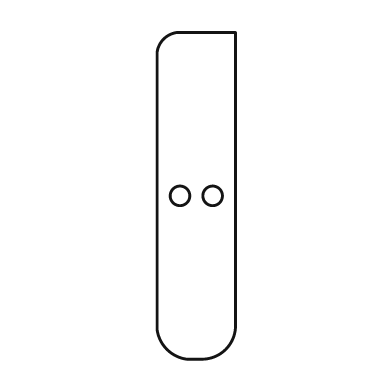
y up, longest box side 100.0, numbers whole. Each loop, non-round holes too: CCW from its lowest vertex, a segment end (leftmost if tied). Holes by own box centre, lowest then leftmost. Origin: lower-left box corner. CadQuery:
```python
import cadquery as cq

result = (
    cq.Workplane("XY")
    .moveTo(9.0, 0.0)
    .lineTo(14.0, 0.0)
    .threePointArc((21.0, 3.0), (24.0, 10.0))
    .lineTo(24.0, 100.0)
    .lineTo(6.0, 100.0)
    .threePointArc((2.0, 98.0), (0.0, 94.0))
    .lineTo(0.0, 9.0)
    .threePointArc((3.0, 3.0), (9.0, 0.0))
    .close()
    .moveTo(7.0, 50.0)
    .circle(3.0)
    .moveTo(17.0, 50.0)
    .circle(3.0)
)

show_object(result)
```